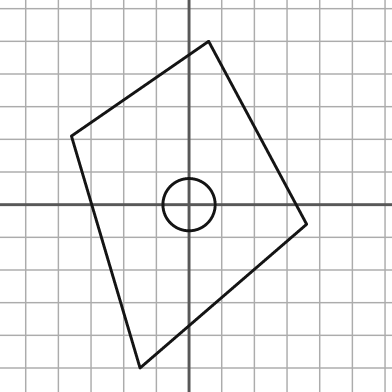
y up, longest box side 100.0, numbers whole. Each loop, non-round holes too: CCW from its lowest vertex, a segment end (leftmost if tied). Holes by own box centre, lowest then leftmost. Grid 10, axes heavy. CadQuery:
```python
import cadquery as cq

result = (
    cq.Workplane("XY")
    .moveTo(-15.0, -50.0)
    .lineTo(36.0, -6.0)
    .lineTo(6.0, 50.0)
    .lineTo(-36.0, 21.0)
    .close()
    .moveTo(0.0, 0.0)
    .circle(8.0)
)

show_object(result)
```